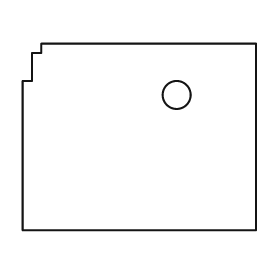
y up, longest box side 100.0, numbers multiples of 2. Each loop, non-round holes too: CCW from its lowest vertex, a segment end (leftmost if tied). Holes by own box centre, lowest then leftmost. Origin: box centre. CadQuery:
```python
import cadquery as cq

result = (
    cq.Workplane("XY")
    .moveTo(-50.0, -40.0)
    .lineTo(50.0, -40.0)
    .lineTo(50.0, 40.0)
    .lineTo(-42.0, 40.0)
    .lineTo(-42.0, 36.0)
    .lineTo(-46.0, 36.0)
    .lineTo(-46.0, 24.0)
    .lineTo(-50.0, 24.0)
    .close()
    .moveTo(16.0, 18.0)
    .circle(6.0)
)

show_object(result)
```